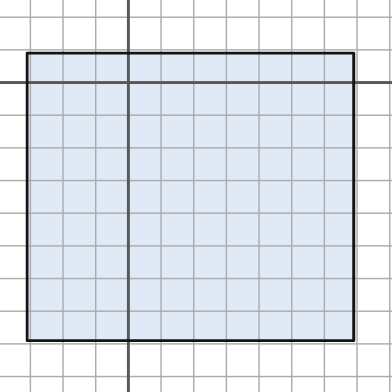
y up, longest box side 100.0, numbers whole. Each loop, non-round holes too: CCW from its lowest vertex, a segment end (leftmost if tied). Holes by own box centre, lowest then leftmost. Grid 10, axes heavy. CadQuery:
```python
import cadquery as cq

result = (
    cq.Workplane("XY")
    .moveTo(-31.0, -79.0)
    .lineTo(69.0, -79.0)
    .lineTo(69.0, 9.0)
    .lineTo(-31.0, 9.0)
    .close()
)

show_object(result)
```